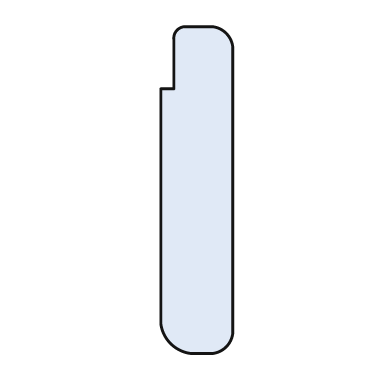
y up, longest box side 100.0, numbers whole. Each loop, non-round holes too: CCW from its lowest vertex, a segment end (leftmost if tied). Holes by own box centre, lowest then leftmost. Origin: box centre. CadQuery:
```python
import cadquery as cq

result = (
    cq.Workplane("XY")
    .moveTo(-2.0, -50.0)
    .lineTo(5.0, -50.0)
    .threePointArc((9.0, -48.0), (11.0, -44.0))
    .lineTo(11.0, 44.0)
    .threePointArc((9.0, 48.0), (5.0, 50.0))
    .lineTo(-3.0, 50.0)
    .threePointArc((-6.0, 49.0), (-7.0, 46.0))
    .lineTo(-7.0, 31.0)
    .lineTo(-11.0, 31.0)
    .lineTo(-11.0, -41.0)
    .threePointArc((-8.0, -47.0), (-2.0, -50.0))
    .close()
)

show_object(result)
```